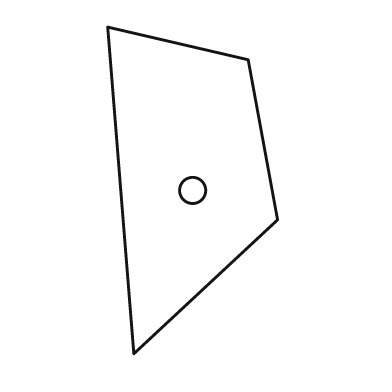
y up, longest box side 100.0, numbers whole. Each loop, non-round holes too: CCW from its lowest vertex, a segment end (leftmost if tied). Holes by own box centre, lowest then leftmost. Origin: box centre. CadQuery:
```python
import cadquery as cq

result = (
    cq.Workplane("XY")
    .moveTo(-18.0, -50.0)
    .lineTo(26.0, -9.0)
    .lineTo(17.0, 40.0)
    .lineTo(-26.0, 50.0)
    .close()
    .moveTo(0.0, 0.0)
    .circle(4.0)
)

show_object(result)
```